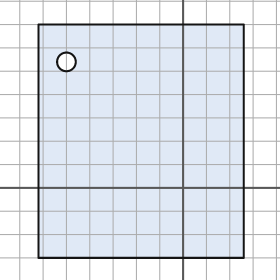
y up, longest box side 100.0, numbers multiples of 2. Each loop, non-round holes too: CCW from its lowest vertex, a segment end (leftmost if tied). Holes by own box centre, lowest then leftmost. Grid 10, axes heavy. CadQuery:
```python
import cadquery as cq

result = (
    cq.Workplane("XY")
    .moveTo(-62.0, -30.0)
    .lineTo(26.0, -30.0)
    .lineTo(26.0, 70.0)
    .lineTo(-62.0, 70.0)
    .close()
    .moveTo(-50.0, 54.0)
    .circle(4.0)
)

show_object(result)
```